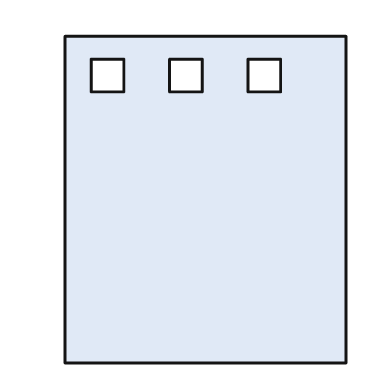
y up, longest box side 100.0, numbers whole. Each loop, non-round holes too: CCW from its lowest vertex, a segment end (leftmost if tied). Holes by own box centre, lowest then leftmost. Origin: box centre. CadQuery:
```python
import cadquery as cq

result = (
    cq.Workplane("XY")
    .moveTo(-43.0, -50.0)
    .lineTo(43.0, -50.0)
    .lineTo(43.0, 50.0)
    .lineTo(-43.0, 50.0)
    .close()
    .moveTo(-35.0, 33.0)
    .lineTo(-25.0, 33.0)
    .lineTo(-25.0, 43.0)
    .lineTo(-35.0, 43.0)
    .close()
    .moveTo(-11.0, 33.0)
    .lineTo(-1.0, 33.0)
    .lineTo(-1.0, 43.0)
    .lineTo(-11.0, 43.0)
    .close()
    .moveTo(13.0, 33.0)
    .lineTo(23.0, 33.0)
    .lineTo(23.0, 43.0)
    .lineTo(13.0, 43.0)
    .close()
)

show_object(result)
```